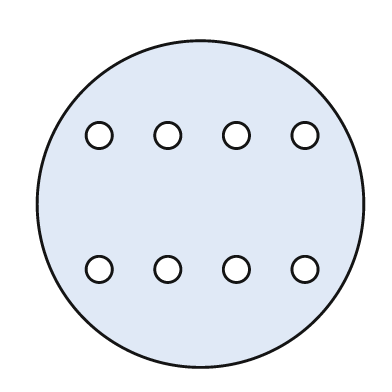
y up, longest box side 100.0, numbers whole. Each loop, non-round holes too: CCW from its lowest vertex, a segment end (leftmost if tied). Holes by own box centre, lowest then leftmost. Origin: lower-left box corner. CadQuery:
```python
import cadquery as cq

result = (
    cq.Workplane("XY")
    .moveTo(50.0, 50.0)
    .circle(50.0)
    .moveTo(19.0, 30.0)
    .circle(4.0)
    .moveTo(40.0, 30.0)
    .circle(4.0)
    .moveTo(61.0, 30.0)
    .circle(4.0)
    .moveTo(82.0, 30.0)
    .circle(4.0)
    .moveTo(19.0, 71.0)
    .circle(4.0)
    .moveTo(40.0, 71.0)
    .circle(4.0)
    .moveTo(61.0, 71.0)
    .circle(4.0)
    .moveTo(82.0, 71.0)
    .circle(4.0)
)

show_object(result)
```